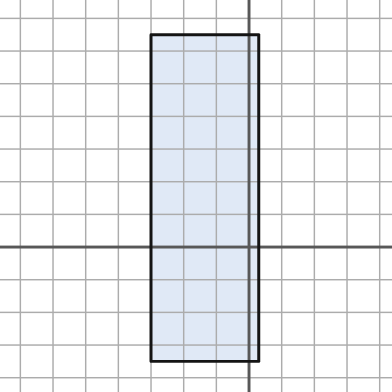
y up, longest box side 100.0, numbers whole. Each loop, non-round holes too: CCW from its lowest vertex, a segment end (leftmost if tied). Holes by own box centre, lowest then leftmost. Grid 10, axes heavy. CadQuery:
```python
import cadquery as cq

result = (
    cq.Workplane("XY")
    .moveTo(-30.0, -35.0)
    .lineTo(3.0, -35.0)
    .lineTo(3.0, 65.0)
    .lineTo(-30.0, 65.0)
    .close()
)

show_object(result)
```